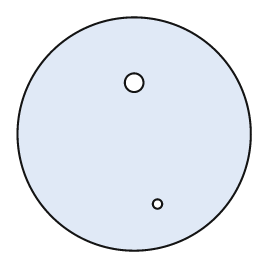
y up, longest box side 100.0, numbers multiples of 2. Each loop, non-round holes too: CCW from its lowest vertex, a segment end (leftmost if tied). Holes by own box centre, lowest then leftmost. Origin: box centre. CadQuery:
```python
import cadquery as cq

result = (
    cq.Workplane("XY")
    .moveTo(0.0, 0.0)
    .circle(50.0)
    .moveTo(10.0, -30.0)
    .circle(2.0)
    .moveTo(0.0, 22.0)
    .circle(4.0)
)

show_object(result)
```